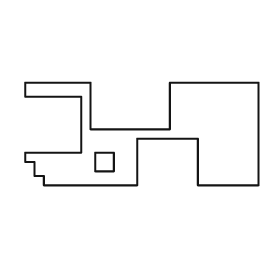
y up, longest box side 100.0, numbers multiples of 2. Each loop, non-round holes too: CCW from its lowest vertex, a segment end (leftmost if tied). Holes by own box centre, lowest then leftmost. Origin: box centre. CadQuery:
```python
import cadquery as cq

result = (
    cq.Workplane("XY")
    .moveTo(-42.0, -22.0)
    .lineTo(-2.0, -22.0)
    .lineTo(-2.0, -2.0)
    .lineTo(24.0, -2.0)
    .lineTo(24.0, -22.0)
    .lineTo(50.0, -22.0)
    .lineTo(50.0, 22.0)
    .lineTo(12.0, 22.0)
    .lineTo(12.0, 2.0)
    .lineTo(-22.0, 2.0)
    .lineTo(-22.0, 22.0)
    .lineTo(-50.0, 22.0)
    .lineTo(-50.0, 16.0)
    .lineTo(-26.0, 16.0)
    .lineTo(-26.0, -8.0)
    .lineTo(-50.0, -8.0)
    .lineTo(-50.0, -12.0)
    .lineTo(-46.0, -12.0)
    .lineTo(-46.0, -18.0)
    .lineTo(-42.0, -18.0)
    .close()
    .moveTo(-20.0, -16.0)
    .lineTo(-12.0, -16.0)
    .lineTo(-12.0, -8.0)
    .lineTo(-20.0, -8.0)
    .close()
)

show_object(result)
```